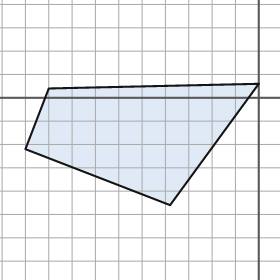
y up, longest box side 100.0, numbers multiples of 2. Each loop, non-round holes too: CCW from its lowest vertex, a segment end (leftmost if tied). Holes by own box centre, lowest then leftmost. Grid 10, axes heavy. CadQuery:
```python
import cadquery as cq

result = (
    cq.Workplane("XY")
    .moveTo(-38.0, -46.0)
    .lineTo(0.0, 6.0)
    .lineTo(-90.0, 4.0)
    .lineTo(-100.0, -22.0)
    .close()
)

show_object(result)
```